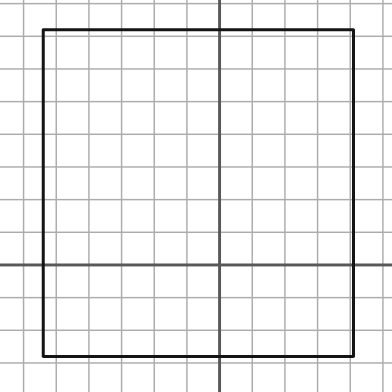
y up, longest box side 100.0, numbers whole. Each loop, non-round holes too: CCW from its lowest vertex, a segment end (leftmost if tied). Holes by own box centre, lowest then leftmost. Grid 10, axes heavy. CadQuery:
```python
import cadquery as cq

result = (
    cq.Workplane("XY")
    .moveTo(-54.0, -28.0)
    .lineTo(41.0, -28.0)
    .lineTo(41.0, 72.0)
    .lineTo(-54.0, 72.0)
    .close()
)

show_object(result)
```